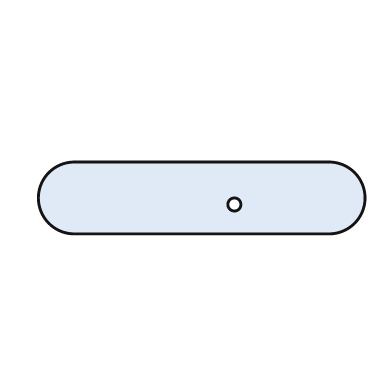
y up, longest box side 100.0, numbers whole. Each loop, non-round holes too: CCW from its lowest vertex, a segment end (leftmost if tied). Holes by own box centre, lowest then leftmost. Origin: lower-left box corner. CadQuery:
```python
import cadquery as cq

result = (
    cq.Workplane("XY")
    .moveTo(11.0, 0.0)
    .lineTo(89.0, 0.0)
    .threePointArc((100.0, 11.0), (89.0, 22.0))
    .lineTo(11.0, 22.0)
    .threePointArc((0.0, 11.0), (11.0, 0.0))
    .close()
    .moveTo(60.0, 9.0)
    .circle(2.0)
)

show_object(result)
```